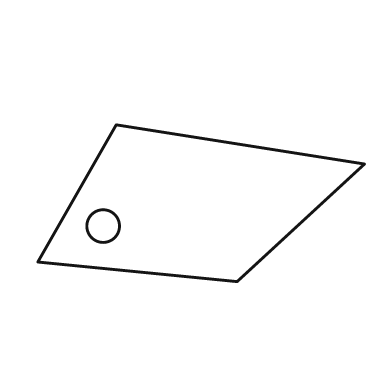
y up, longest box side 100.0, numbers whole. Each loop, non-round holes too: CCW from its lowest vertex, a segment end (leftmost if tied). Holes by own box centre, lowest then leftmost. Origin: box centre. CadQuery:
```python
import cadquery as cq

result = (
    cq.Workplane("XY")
    .moveTo(11.0, -24.0)
    .lineTo(50.0, 12.0)
    .lineTo(-26.0, 24.0)
    .lineTo(-50.0, -18.0)
    .close()
    .moveTo(-30.0, -7.0)
    .circle(5.0)
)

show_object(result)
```